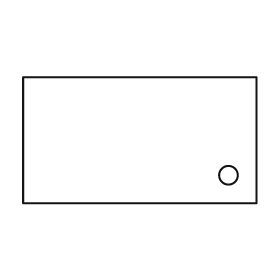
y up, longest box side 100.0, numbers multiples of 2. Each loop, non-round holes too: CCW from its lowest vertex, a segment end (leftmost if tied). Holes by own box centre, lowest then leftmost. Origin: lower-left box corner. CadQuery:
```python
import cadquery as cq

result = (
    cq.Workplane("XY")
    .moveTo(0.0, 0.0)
    .lineTo(100.0, 0.0)
    .lineTo(100.0, 54.0)
    .lineTo(0.0, 54.0)
    .close()
    .moveTo(88.0, 12.0)
    .circle(4.0)
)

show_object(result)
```